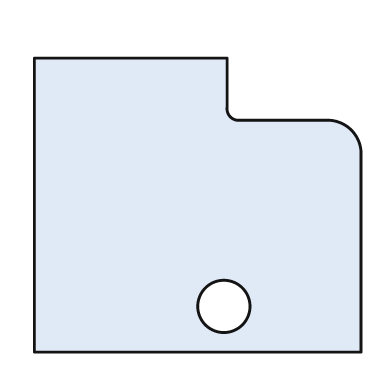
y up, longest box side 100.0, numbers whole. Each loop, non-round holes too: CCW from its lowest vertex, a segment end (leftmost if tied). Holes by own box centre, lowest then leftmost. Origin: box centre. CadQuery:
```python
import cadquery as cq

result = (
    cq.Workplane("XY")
    .moveTo(-50.0, -45.0)
    .lineTo(50.0, -45.0)
    .lineTo(50.0, 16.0)
    .threePointArc((47.0, 23.0), (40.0, 26.0))
    .lineTo(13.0, 26.0)
    .threePointArc((10.0, 27.0), (9.0, 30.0))
    .lineTo(9.0, 45.0)
    .lineTo(-50.0, 45.0)
    .close()
    .moveTo(8.0, -31.0)
    .circle(8.0)
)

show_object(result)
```